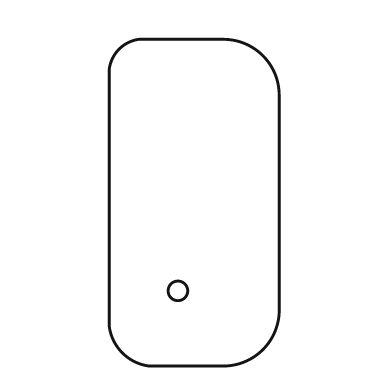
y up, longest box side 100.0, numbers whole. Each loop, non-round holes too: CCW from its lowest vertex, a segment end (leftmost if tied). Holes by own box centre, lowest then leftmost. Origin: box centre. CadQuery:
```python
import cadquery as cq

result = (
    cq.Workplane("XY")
    .moveTo(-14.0, -50.0)
    .lineTo(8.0, -50.0)
    .threePointArc((21.0, -45.0), (26.0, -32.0))
    .lineTo(26.0, 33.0)
    .threePointArc((21.0, 45.0), (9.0, 50.0))
    .lineTo(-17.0, 50.0)
    .threePointArc((-23.0, 47.0), (-26.0, 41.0))
    .lineTo(-26.0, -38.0)
    .threePointArc((-22.0, -46.0), (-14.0, -50.0))
    .close()
    .moveTo(-5.0, -27.0)
    .circle(3.0)
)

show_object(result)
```